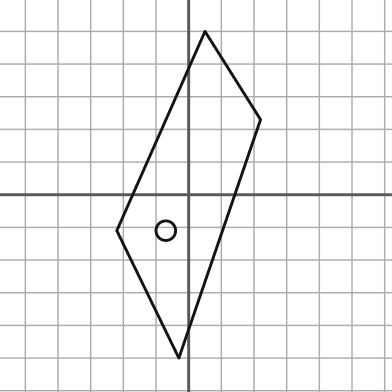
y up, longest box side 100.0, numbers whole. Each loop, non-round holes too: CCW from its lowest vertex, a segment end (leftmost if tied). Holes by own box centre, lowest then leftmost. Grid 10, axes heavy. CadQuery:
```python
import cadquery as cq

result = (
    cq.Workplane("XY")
    .moveTo(-3.0, -50.0)
    .lineTo(22.0, 23.0)
    .lineTo(5.0, 50.0)
    .lineTo(-22.0, -11.0)
    .close()
    .moveTo(-7.0, -11.0)
    .circle(3.0)
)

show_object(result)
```